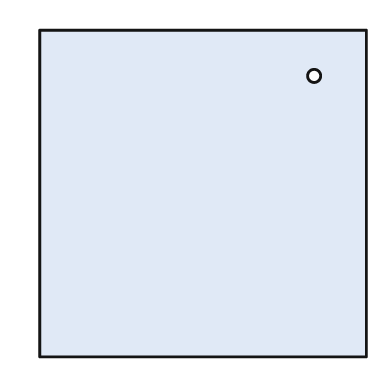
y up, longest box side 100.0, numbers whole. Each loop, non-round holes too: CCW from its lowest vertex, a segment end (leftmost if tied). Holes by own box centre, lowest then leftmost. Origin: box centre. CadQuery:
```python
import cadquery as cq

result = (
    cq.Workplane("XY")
    .moveTo(-50.0, -50.0)
    .lineTo(50.0, -50.0)
    .lineTo(50.0, 50.0)
    .lineTo(-50.0, 50.0)
    .close()
    .moveTo(34.0, 36.0)
    .circle(2.0)
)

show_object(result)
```